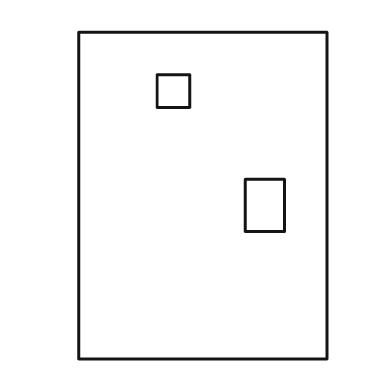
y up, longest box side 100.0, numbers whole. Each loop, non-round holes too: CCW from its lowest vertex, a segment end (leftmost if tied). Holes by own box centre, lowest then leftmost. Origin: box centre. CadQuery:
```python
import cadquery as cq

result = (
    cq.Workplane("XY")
    .moveTo(-38.0, -50.0)
    .lineTo(38.0, -50.0)
    .lineTo(38.0, 50.0)
    .lineTo(-38.0, 50.0)
    .close()
    .moveTo(13.0, -11.0)
    .lineTo(25.0, -11.0)
    .lineTo(25.0, 5.0)
    .lineTo(13.0, 5.0)
    .close()
    .moveTo(-14.0, 27.0)
    .lineTo(-4.0, 27.0)
    .lineTo(-4.0, 37.0)
    .lineTo(-14.0, 37.0)
    .close()
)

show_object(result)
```